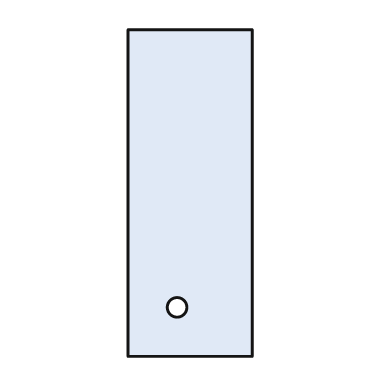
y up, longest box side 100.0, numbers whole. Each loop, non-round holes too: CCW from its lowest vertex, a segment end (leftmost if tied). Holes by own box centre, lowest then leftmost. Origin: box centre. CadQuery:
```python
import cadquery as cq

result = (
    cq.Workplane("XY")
    .moveTo(-19.0, -50.0)
    .lineTo(19.0, -50.0)
    .lineTo(19.0, 50.0)
    .lineTo(-19.0, 50.0)
    .close()
    .moveTo(-4.0, -35.0)
    .circle(3.0)
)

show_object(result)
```